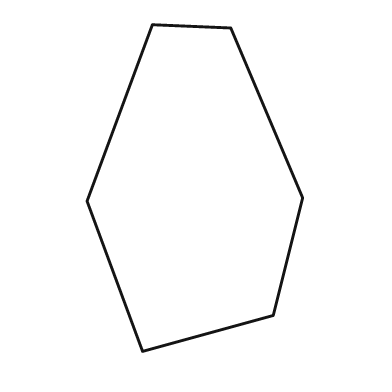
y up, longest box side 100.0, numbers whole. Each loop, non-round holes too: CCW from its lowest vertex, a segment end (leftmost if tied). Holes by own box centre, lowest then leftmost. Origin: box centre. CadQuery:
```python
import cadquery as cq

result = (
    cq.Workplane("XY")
    .moveTo(-16.0, -50.0)
    .lineTo(24.0, -39.0)
    .lineTo(33.0, -3.0)
    .lineTo(11.0, 49.0)
    .lineTo(-13.0, 50.0)
    .lineTo(-33.0, -4.0)
    .close()
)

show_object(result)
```